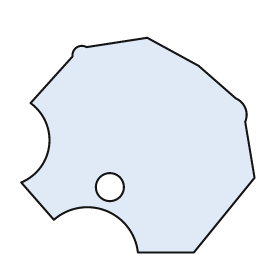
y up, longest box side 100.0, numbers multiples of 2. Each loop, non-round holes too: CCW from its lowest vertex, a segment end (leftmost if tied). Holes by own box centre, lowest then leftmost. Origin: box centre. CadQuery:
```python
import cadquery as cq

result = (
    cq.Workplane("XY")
    .moveTo(0.0, -46.0)
    .lineTo(24.0, -46.0)
    .lineTo(50.0, -14.0)
    .lineTo(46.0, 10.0)
    .threePointArc((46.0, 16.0), (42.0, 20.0))
    .lineTo(26.0, 34.0)
    .lineTo(4.0, 46.0)
    .lineTo(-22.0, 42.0)
    .threePointArc((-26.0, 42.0), (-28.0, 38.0))
    .lineTo(-46.0, 18.0)
    .threePointArc((-38.0, 0.0), (-50.0, -16.0))
    .lineTo(-36.0, -32.0)
    .threePointArc((-14.0, -28.0), (0.0, -46.0))
    .close()
    .moveTo(-12.0, -18.0)
    .circle(6.0)
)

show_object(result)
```